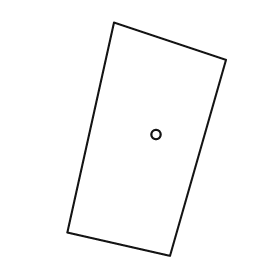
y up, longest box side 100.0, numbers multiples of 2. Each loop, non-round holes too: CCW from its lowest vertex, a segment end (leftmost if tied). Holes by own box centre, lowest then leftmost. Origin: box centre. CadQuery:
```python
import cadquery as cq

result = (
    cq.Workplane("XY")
    .moveTo(10.0, -50.0)
    .lineTo(34.0, 34.0)
    .lineTo(-14.0, 50.0)
    .lineTo(-34.0, -40.0)
    .close()
    .moveTo(4.0, 2.0)
    .circle(2.0)
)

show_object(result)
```